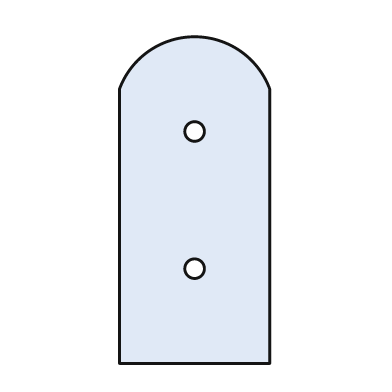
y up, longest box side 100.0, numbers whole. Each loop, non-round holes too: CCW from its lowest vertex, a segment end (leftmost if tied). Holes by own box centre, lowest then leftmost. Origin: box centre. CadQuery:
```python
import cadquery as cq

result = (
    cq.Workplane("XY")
    .moveTo(-23.0, -50.0)
    .lineTo(23.0, -50.0)
    .lineTo(23.0, 34.0)
    .threePointArc((0.0, 50.0), (-23.0, 34.0))
    .close()
    .moveTo(0.0, -21.0)
    .circle(3.0)
    .moveTo(0.0, 21.0)
    .circle(3.0)
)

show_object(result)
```